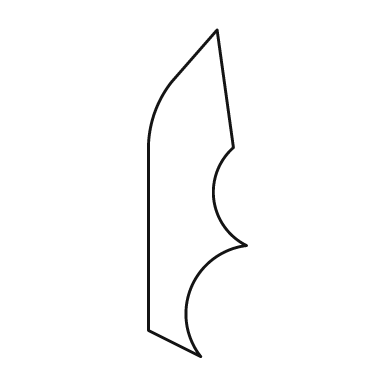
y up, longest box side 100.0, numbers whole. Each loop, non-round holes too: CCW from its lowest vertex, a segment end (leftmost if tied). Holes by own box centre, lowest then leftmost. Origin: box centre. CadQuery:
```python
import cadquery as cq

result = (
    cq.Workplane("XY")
    .moveTo(1.0, -50.0)
    .threePointArc((-2.0, -29.0), (15.0, -16.0))
    .threePointArc((5.0, -2.0), (11.0, 14.0))
    .lineTo(6.0, 50.0)
    .lineTo(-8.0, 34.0)
    .threePointArc((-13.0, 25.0), (-15.0, 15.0))
    .lineTo(-15.0, -42.0)
    .close()
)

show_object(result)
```